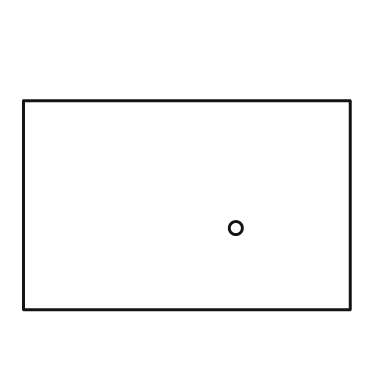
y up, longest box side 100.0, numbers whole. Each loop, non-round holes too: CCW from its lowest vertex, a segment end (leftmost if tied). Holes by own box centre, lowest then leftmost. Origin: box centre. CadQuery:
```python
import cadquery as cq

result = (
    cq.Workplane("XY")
    .moveTo(-50.0, -32.0)
    .lineTo(50.0, -32.0)
    .lineTo(50.0, 32.0)
    .lineTo(-50.0, 32.0)
    .close()
    .moveTo(15.0, -7.0)
    .circle(2.0)
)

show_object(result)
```